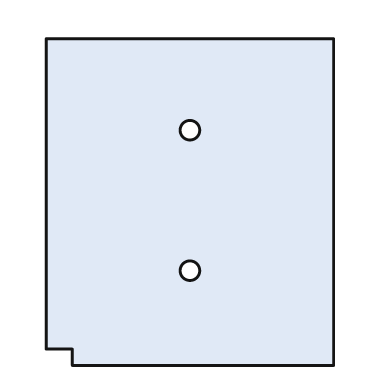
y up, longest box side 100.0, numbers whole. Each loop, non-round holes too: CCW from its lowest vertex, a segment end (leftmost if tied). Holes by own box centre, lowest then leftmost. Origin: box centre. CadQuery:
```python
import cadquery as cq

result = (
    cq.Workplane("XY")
    .moveTo(-36.0, -50.0)
    .lineTo(44.0, -50.0)
    .lineTo(44.0, 50.0)
    .lineTo(-44.0, 50.0)
    .lineTo(-44.0, -45.0)
    .lineTo(-36.0, -45.0)
    .close()
    .moveTo(0.0, -21.0)
    .circle(3.0)
    .moveTo(0.0, 22.0)
    .circle(3.0)
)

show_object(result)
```